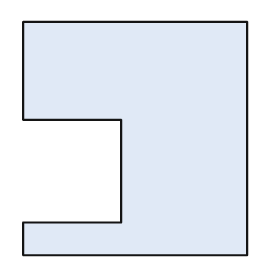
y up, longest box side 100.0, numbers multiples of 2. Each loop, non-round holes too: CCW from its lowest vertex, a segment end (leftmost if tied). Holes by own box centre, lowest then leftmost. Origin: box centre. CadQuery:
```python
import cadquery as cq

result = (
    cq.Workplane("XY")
    .moveTo(-48.0, -50.0)
    .lineTo(48.0, -50.0)
    .lineTo(48.0, 50.0)
    .lineTo(-48.0, 50.0)
    .lineTo(-48.0, 8.0)
    .lineTo(-6.0, 8.0)
    .lineTo(-6.0, -36.0)
    .lineTo(-48.0, -36.0)
    .close()
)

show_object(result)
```